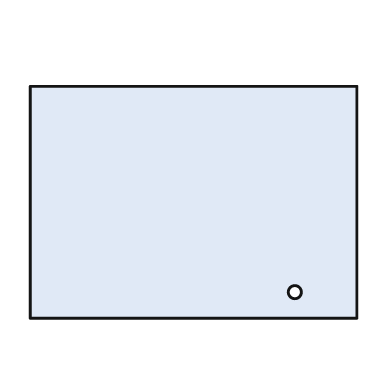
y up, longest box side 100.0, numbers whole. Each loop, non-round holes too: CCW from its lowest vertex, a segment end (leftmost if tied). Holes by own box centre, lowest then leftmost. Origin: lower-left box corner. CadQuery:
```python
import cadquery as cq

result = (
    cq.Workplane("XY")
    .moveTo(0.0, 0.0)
    .lineTo(100.0, 0.0)
    .lineTo(100.0, 71.0)
    .lineTo(0.0, 71.0)
    .close()
    .moveTo(81.0, 8.0)
    .circle(2.0)
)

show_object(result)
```